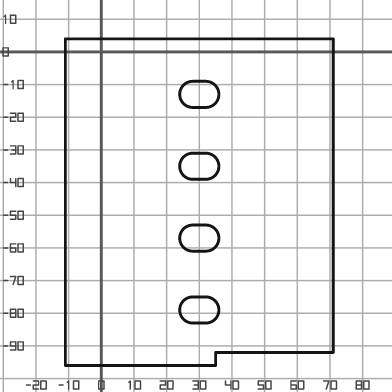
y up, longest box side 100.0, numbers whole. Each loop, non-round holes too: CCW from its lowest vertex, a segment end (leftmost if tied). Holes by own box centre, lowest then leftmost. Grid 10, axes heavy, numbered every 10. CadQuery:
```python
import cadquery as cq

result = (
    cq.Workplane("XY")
    .moveTo(-11.0, -96.0)
    .lineTo(35.0, -96.0)
    .lineTo(35.0, -92.0)
    .lineTo(71.0, -92.0)
    .lineTo(71.0, 4.0)
    .lineTo(-11.0, 4.0)
    .close()
    .moveTo(28.0, -83.0)
    .lineTo(32.0, -83.0)
    .threePointArc((36.0, -79.0), (32.0, -75.0))
    .lineTo(28.0, -75.0)
    .threePointArc((24.0, -79.0), (28.0, -83.0))
    .close()
    .moveTo(28.0, -61.0)
    .lineTo(32.0, -61.0)
    .threePointArc((36.0, -57.0), (32.0, -53.0))
    .lineTo(28.0, -53.0)
    .threePointArc((24.0, -57.0), (28.0, -61.0))
    .close()
    .moveTo(28.0, -39.0)
    .lineTo(32.0, -39.0)
    .threePointArc((36.0, -35.0), (32.0, -31.0))
    .lineTo(28.0, -31.0)
    .threePointArc((24.0, -35.0), (28.0, -39.0))
    .close()
    .moveTo(28.0, -17.0)
    .lineTo(32.0, -17.0)
    .threePointArc((36.0, -13.0), (32.0, -9.0))
    .lineTo(28.0, -9.0)
    .threePointArc((24.0, -13.0), (28.0, -17.0))
    .close()
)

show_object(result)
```